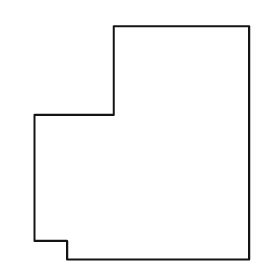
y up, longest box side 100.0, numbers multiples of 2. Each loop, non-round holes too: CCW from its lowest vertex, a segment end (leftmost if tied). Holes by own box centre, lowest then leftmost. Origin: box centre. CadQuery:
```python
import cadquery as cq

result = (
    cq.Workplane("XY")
    .moveTo(-32.0, -50.0)
    .lineTo(46.0, -50.0)
    .lineTo(46.0, 50.0)
    .lineTo(-12.0, 50.0)
    .lineTo(-12.0, 12.0)
    .lineTo(-46.0, 12.0)
    .lineTo(-46.0, -42.0)
    .lineTo(-32.0, -42.0)
    .close()
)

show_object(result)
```